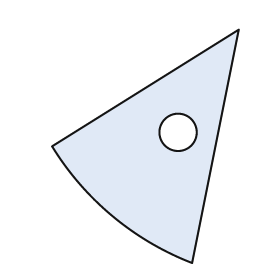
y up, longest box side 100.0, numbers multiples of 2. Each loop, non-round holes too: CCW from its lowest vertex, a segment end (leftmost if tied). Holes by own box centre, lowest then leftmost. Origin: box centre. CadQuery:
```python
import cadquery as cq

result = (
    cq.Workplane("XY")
    .moveTo(20.0, -50.0)
    .lineTo(40.0, 50.0)
    .lineTo(-40.0, 0.0)
    .threePointArc((-14.0, -30.0), (20.0, -50.0))
    .close()
    .moveTo(14.0, 6.0)
    .circle(8.0)
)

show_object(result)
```